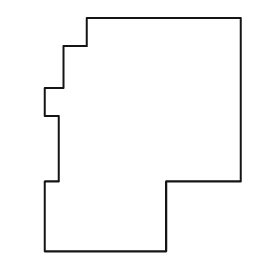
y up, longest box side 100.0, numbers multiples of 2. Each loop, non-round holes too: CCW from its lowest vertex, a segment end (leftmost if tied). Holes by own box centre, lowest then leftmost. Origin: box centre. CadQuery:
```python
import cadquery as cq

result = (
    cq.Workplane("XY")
    .moveTo(-42.0, -50.0)
    .lineTo(10.0, -50.0)
    .lineTo(10.0, -20.0)
    .lineTo(42.0, -20.0)
    .lineTo(42.0, 50.0)
    .lineTo(-24.0, 50.0)
    .lineTo(-24.0, 38.0)
    .lineTo(-34.0, 38.0)
    .lineTo(-34.0, 20.0)
    .lineTo(-42.0, 20.0)
    .lineTo(-42.0, 8.0)
    .lineTo(-36.0, 8.0)
    .lineTo(-36.0, -20.0)
    .lineTo(-42.0, -20.0)
    .close()
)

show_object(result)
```